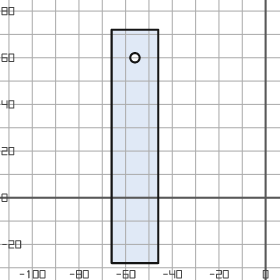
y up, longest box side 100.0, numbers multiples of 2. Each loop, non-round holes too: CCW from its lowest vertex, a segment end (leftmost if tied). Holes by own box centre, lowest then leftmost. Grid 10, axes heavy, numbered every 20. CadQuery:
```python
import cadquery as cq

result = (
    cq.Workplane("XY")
    .moveTo(-66.0, -28.0)
    .lineTo(-46.0, -28.0)
    .lineTo(-46.0, 72.0)
    .lineTo(-66.0, 72.0)
    .close()
    .moveTo(-56.0, 60.0)
    .circle(2.0)
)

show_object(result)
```